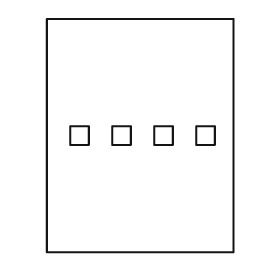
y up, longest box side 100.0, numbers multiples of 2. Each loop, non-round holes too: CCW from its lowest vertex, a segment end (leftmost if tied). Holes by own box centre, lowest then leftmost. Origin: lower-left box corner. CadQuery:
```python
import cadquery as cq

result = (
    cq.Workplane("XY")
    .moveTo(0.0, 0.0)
    .lineTo(80.0, 0.0)
    .lineTo(80.0, 100.0)
    .lineTo(0.0, 100.0)
    .close()
    .moveTo(10.0, 46.0)
    .lineTo(18.0, 46.0)
    .lineTo(18.0, 54.0)
    .lineTo(10.0, 54.0)
    .close()
    .moveTo(28.0, 46.0)
    .lineTo(36.0, 46.0)
    .lineTo(36.0, 54.0)
    .lineTo(28.0, 54.0)
    .close()
    .moveTo(46.0, 46.0)
    .lineTo(54.0, 46.0)
    .lineTo(54.0, 54.0)
    .lineTo(46.0, 54.0)
    .close()
    .moveTo(64.0, 46.0)
    .lineTo(72.0, 46.0)
    .lineTo(72.0, 54.0)
    .lineTo(64.0, 54.0)
    .close()
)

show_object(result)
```